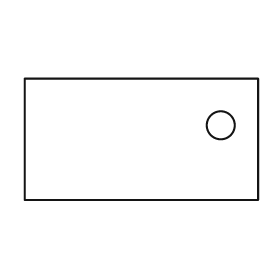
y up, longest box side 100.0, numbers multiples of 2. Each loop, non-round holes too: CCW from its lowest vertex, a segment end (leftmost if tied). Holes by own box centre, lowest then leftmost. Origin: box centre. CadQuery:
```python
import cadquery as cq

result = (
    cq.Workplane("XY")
    .moveTo(-50.0, -26.0)
    .lineTo(50.0, -26.0)
    .lineTo(50.0, 26.0)
    .lineTo(-50.0, 26.0)
    .close()
    .moveTo(34.0, 6.0)
    .circle(6.0)
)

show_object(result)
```